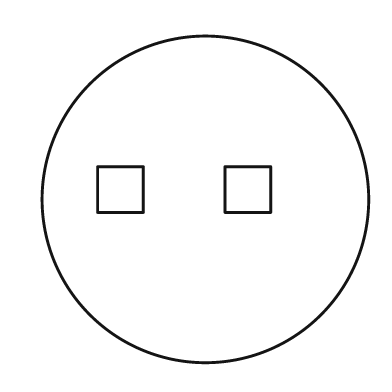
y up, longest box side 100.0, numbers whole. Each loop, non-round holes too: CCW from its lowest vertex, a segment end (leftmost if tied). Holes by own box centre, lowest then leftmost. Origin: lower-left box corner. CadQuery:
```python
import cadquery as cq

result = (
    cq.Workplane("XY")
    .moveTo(50.0, 50.0)
    .circle(50.0)
    .moveTo(17.0, 46.0)
    .lineTo(31.0, 46.0)
    .lineTo(31.0, 60.0)
    .lineTo(17.0, 60.0)
    .close()
    .moveTo(56.0, 46.0)
    .lineTo(70.0, 46.0)
    .lineTo(70.0, 60.0)
    .lineTo(56.0, 60.0)
    .close()
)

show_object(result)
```